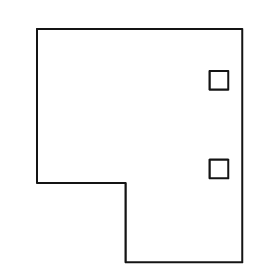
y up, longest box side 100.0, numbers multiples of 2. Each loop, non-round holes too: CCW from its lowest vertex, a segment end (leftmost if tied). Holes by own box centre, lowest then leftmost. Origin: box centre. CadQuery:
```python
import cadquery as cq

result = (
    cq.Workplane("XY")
    .moveTo(-6.0, -50.0)
    .lineTo(44.0, -50.0)
    .lineTo(44.0, 50.0)
    .lineTo(-44.0, 50.0)
    .lineTo(-44.0, -16.0)
    .lineTo(-6.0, -16.0)
    .close()
    .moveTo(30.0, -14.0)
    .lineTo(38.0, -14.0)
    .lineTo(38.0, -6.0)
    .lineTo(30.0, -6.0)
    .close()
    .moveTo(30.0, 24.0)
    .lineTo(38.0, 24.0)
    .lineTo(38.0, 32.0)
    .lineTo(30.0, 32.0)
    .close()
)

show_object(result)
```